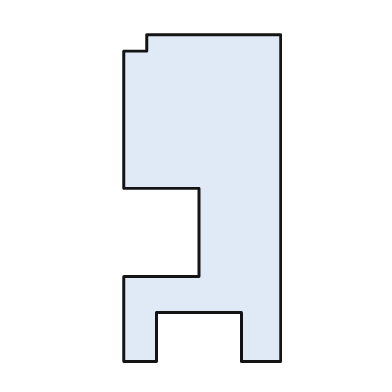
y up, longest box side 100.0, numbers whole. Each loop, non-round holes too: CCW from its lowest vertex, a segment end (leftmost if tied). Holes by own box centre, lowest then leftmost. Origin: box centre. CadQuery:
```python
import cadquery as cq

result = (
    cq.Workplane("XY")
    .moveTo(-24.0, -50.0)
    .lineTo(-14.0, -50.0)
    .lineTo(-14.0, -35.0)
    .lineTo(12.0, -35.0)
    .lineTo(12.0, -50.0)
    .lineTo(24.0, -50.0)
    .lineTo(24.0, 50.0)
    .lineTo(-17.0, 50.0)
    .lineTo(-17.0, 45.0)
    .lineTo(-24.0, 45.0)
    .lineTo(-24.0, 3.0)
    .lineTo(-1.0, 3.0)
    .lineTo(-1.0, -24.0)
    .lineTo(-24.0, -24.0)
    .close()
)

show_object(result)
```